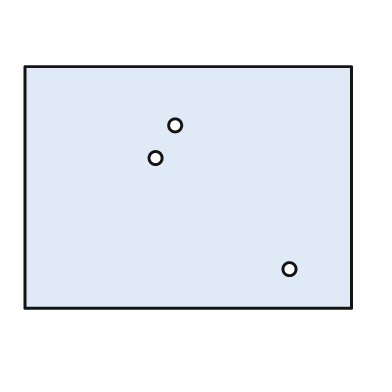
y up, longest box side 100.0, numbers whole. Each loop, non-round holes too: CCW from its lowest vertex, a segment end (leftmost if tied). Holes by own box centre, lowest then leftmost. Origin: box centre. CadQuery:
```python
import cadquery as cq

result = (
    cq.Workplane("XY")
    .moveTo(-50.0, -37.0)
    .lineTo(50.0, -37.0)
    .lineTo(50.0, 37.0)
    .lineTo(-50.0, 37.0)
    .close()
    .moveTo(31.0, -25.0)
    .circle(2.0)
    .moveTo(-10.0, 9.0)
    .circle(2.0)
    .moveTo(-4.0, 19.0)
    .circle(2.0)
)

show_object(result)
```